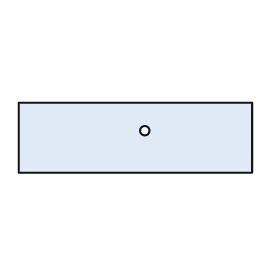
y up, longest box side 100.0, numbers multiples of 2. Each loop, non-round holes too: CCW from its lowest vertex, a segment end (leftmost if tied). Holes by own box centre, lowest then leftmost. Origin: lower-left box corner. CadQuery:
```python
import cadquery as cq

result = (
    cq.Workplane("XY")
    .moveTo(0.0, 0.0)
    .lineTo(100.0, 0.0)
    .lineTo(100.0, 30.0)
    .lineTo(0.0, 30.0)
    .close()
    .moveTo(54.0, 18.0)
    .circle(2.0)
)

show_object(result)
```